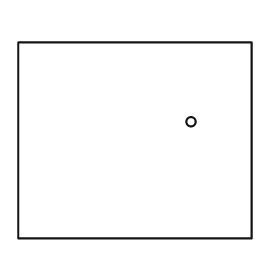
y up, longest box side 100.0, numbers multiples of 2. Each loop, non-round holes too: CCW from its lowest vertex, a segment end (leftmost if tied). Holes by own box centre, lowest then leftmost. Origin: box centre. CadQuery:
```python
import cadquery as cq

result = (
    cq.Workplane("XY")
    .moveTo(-50.0, -42.0)
    .lineTo(50.0, -42.0)
    .lineTo(50.0, 42.0)
    .lineTo(-50.0, 42.0)
    .close()
    .moveTo(24.0, 8.0)
    .circle(2.0)
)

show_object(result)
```